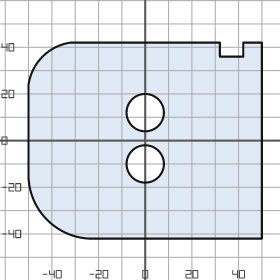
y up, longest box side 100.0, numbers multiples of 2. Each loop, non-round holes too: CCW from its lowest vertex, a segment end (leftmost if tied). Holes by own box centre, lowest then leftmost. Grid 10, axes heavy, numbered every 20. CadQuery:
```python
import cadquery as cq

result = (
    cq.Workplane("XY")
    .moveTo(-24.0, -42.0)
    .lineTo(50.0, -42.0)
    .lineTo(50.0, 42.0)
    .lineTo(42.0, 42.0)
    .lineTo(42.0, 36.0)
    .lineTo(32.0, 36.0)
    .lineTo(32.0, 42.0)
    .lineTo(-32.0, 42.0)
    .threePointArc((-44.0, 36.0), (-50.0, 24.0))
    .lineTo(-50.0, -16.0)
    .threePointArc((-42.0, -34.0), (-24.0, -42.0))
    .close()
    .moveTo(0.0, -10.0)
    .circle(8.0)
    .moveTo(0.0, 12.0)
    .circle(8.0)
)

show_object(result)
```